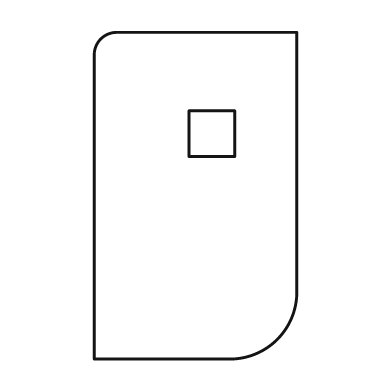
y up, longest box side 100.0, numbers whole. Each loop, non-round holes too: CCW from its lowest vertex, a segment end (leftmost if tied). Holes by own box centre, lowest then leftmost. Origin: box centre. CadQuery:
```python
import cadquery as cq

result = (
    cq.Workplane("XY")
    .moveTo(-31.0, -50.0)
    .lineTo(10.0, -50.0)
    .threePointArc((25.0, -44.0), (31.0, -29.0))
    .lineTo(31.0, 50.0)
    .lineTo(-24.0, 50.0)
    .threePointArc((-29.0, 48.0), (-31.0, 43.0))
    .close()
    .moveTo(-2.0, 12.0)
    .lineTo(12.0, 12.0)
    .lineTo(12.0, 26.0)
    .lineTo(-2.0, 26.0)
    .close()
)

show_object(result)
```